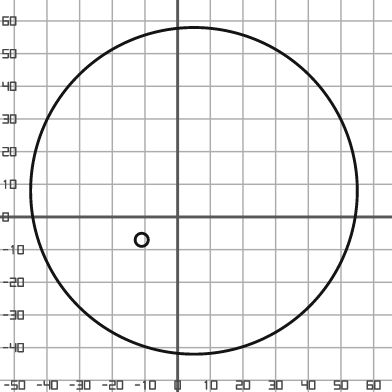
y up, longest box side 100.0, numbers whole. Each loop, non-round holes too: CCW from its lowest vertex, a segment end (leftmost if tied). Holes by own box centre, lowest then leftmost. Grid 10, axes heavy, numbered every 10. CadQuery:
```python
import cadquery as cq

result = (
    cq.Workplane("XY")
    .moveTo(5.0, 8.0)
    .circle(50.0)
    .moveTo(-11.0, -7.0)
    .circle(2.0)
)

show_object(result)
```